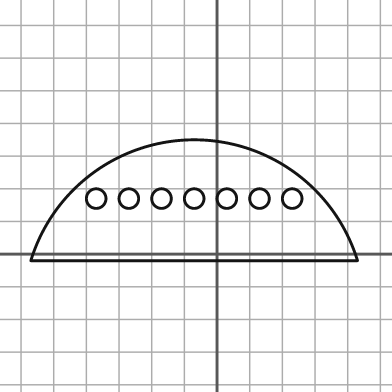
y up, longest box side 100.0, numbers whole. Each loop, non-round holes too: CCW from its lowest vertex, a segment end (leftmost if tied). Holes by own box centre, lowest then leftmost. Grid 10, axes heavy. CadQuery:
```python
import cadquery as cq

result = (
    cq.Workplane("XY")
    .moveTo(-57.0, -2.0)
    .lineTo(43.0, -2.0)
    .threePointArc((-7.0, 35.0), (-57.0, -2.0))
    .close()
    .moveTo(-37.0, 17.0)
    .circle(3.0)
    .moveTo(-27.0, 17.0)
    .circle(3.0)
    .moveTo(-17.0, 17.0)
    .circle(3.0)
    .moveTo(-7.0, 17.0)
    .circle(3.0)
    .moveTo(3.0, 17.0)
    .circle(3.0)
    .moveTo(13.0, 17.0)
    .circle(3.0)
    .moveTo(23.0, 17.0)
    .circle(3.0)
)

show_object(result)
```